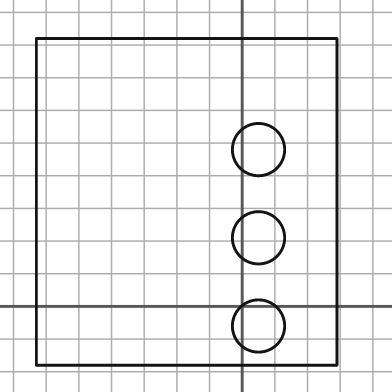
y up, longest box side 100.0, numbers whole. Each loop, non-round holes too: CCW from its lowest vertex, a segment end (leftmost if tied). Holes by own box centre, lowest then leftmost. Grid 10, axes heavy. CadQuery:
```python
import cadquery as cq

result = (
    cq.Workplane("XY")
    .moveTo(-63.0, -18.0)
    .lineTo(29.0, -18.0)
    .lineTo(29.0, 82.0)
    .lineTo(-63.0, 82.0)
    .close()
    .moveTo(5.0, -6.0)
    .circle(8.0)
    .moveTo(5.0, 21.0)
    .circle(8.0)
    .moveTo(5.0, 48.0)
    .circle(8.0)
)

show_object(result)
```